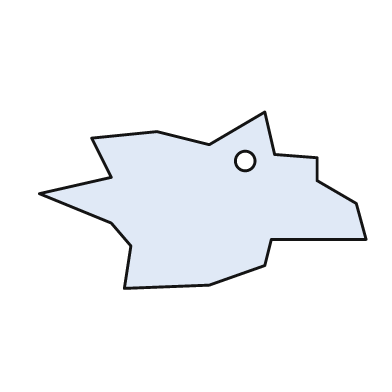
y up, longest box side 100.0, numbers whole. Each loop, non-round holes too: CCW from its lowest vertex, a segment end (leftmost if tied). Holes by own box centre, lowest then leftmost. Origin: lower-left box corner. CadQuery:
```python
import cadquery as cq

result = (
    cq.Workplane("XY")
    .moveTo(26.0, 0.0)
    .lineTo(52.0, 1.0)
    .lineTo(69.0, 7.0)
    .lineTo(71.0, 15.0)
    .lineTo(100.0, 15.0)
    .lineTo(97.0, 26.0)
    .lineTo(85.0, 33.0)
    .lineTo(85.0, 40.0)
    .lineTo(72.0, 41.0)
    .lineTo(69.0, 54.0)
    .lineTo(52.0, 44.0)
    .lineTo(36.0, 48.0)
    .lineTo(16.0, 46.0)
    .lineTo(22.0, 34.0)
    .lineTo(0.0, 29.0)
    .lineTo(22.0, 20.0)
    .lineTo(28.0, 13.0)
    .close()
    .moveTo(63.0, 39.0)
    .circle(3.0)
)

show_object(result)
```